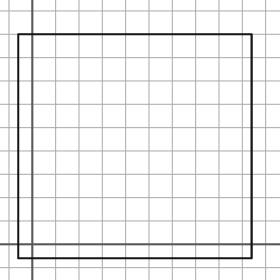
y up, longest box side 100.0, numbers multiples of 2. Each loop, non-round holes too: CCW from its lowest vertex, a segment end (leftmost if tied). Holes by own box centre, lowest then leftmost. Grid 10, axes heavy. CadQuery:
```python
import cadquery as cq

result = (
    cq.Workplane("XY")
    .moveTo(-6.0, -6.0)
    .lineTo(94.0, -6.0)
    .lineTo(94.0, 90.0)
    .lineTo(-6.0, 90.0)
    .close()
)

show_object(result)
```